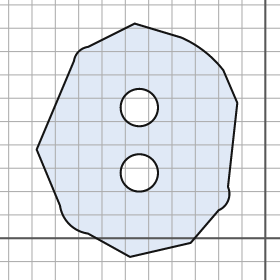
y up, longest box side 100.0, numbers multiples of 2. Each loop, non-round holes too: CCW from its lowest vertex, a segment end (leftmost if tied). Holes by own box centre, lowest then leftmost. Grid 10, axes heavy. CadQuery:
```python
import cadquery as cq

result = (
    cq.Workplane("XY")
    .moveTo(-58.0, -8.0)
    .lineTo(-32.0, -2.0)
    .lineTo(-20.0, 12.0)
    .threePointArc((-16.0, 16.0), (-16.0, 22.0))
    .lineTo(-12.0, 58.0)
    .lineTo(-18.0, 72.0)
    .threePointArc((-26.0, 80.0), (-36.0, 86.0))
    .lineTo(-56.0, 92.0)
    .lineTo(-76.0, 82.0)
    .threePointArc((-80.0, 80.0), (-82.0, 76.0))
    .lineTo(-98.0, 38.0)
    .lineTo(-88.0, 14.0)
    .threePointArc((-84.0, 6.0), (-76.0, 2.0))
    .close()
    .moveTo(-54.0, 28.0)
    .circle(8.0)
    .moveTo(-54.0, 56.0)
    .circle(8.0)
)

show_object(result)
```